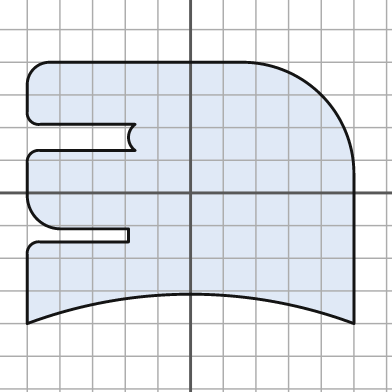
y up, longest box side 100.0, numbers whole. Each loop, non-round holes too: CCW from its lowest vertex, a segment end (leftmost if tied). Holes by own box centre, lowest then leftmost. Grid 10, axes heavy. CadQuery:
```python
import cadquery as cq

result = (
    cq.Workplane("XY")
    .moveTo(-50.0, -40.0)
    .threePointArc((0.0, -31.0), (50.0, -40.0))
    .lineTo(50.0, 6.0)
    .threePointArc((40.0, 30.0), (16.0, 40.0))
    .lineTo(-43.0, 40.0)
    .threePointArc((-48.0, 38.0), (-50.0, 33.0))
    .lineTo(-50.0, 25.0)
    .threePointArc((-49.0, 22.0), (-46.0, 21.0))
    .lineTo(-17.0, 21.0)
    .threePointArc((-19.0, 17.0), (-17.0, 13.0))
    .lineTo(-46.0, 13.0)
    .threePointArc((-49.0, 12.0), (-50.0, 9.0))
    .lineTo(-50.0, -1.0)
    .threePointArc((-47.0, -8.0), (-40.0, -11.0))
    .lineTo(-19.0, -11.0)
    .lineTo(-19.0, -15.0)
    .lineTo(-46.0, -15.0)
    .threePointArc((-49.0, -16.0), (-50.0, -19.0))
    .close()
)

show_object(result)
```